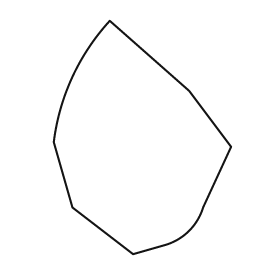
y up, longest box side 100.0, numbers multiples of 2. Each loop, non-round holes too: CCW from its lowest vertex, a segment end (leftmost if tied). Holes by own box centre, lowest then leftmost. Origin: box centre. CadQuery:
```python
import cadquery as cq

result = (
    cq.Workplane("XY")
    .moveTo(-4.0, -50.0)
    .lineTo(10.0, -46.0)
    .threePointArc((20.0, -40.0), (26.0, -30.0))
    .lineTo(38.0, -4.0)
    .lineTo(20.0, 20.0)
    .lineTo(-14.0, 50.0)
    .threePointArc((-30.0, 26.0), (-38.0, -2.0))
    .lineTo(-30.0, -30.0)
    .close()
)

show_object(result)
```